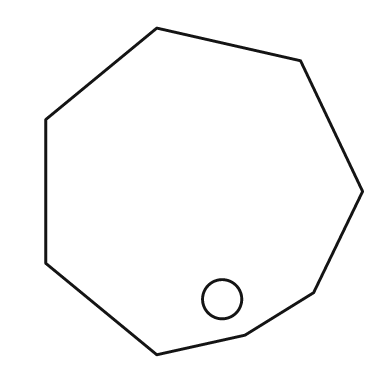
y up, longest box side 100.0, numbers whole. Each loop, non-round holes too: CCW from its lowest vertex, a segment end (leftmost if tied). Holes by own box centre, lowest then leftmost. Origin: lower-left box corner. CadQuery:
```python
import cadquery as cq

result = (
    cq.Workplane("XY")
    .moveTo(34.0, 0.0)
    .lineTo(61.0, 6.0)
    .lineTo(82.0, 19.0)
    .lineTo(97.0, 50.0)
    .lineTo(78.0, 90.0)
    .lineTo(34.0, 100.0)
    .lineTo(0.0, 72.0)
    .lineTo(0.0, 28.0)
    .close()
    .moveTo(54.0, 17.0)
    .circle(6.0)
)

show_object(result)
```